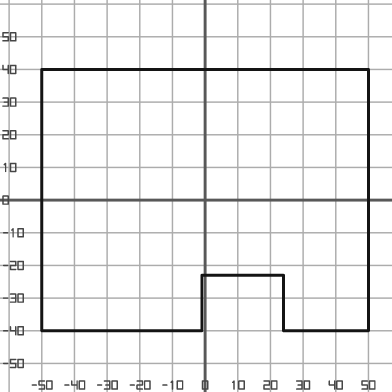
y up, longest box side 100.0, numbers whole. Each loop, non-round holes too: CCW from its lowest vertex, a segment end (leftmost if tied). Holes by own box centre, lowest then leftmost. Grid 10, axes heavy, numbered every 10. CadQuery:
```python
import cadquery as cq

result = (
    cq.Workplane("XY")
    .moveTo(-50.0, -40.0)
    .lineTo(-1.0, -40.0)
    .lineTo(-1.0, -23.0)
    .lineTo(24.0, -23.0)
    .lineTo(24.0, -40.0)
    .lineTo(50.0, -40.0)
    .lineTo(50.0, 40.0)
    .lineTo(-50.0, 40.0)
    .close()
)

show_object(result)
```